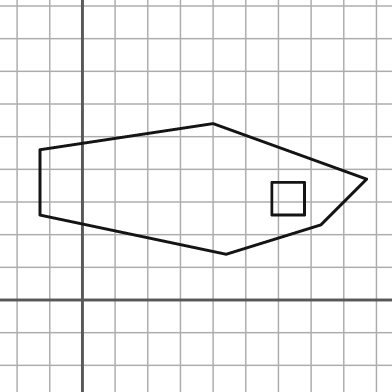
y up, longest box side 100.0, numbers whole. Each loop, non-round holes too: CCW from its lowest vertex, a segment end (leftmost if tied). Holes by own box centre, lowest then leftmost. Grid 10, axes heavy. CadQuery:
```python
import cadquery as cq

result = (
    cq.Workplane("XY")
    .moveTo(44.0, 14.0)
    .lineTo(73.0, 23.0)
    .lineTo(87.0, 37.0)
    .lineTo(40.0, 54.0)
    .lineTo(-13.0, 46.0)
    .lineTo(-13.0, 26.0)
    .close()
    .moveTo(58.0, 26.0)
    .lineTo(68.0, 26.0)
    .lineTo(68.0, 36.0)
    .lineTo(58.0, 36.0)
    .close()
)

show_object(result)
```